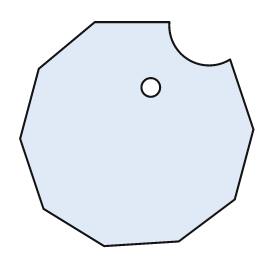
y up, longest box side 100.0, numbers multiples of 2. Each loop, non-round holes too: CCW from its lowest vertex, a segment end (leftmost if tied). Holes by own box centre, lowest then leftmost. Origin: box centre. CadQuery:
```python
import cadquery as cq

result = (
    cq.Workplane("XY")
    .moveTo(-14.0, -48.0)
    .lineTo(18.0, -46.0)
    .lineTo(42.0, -28.0)
    .lineTo(50.0, 2.0)
    .lineTo(40.0, 32.0)
    .threePointArc((22.0, 32.0), (14.0, 48.0))
    .lineTo(-18.0, 48.0)
    .lineTo(-42.0, 28.0)
    .lineTo(-50.0, -2.0)
    .lineTo(-40.0, -32.0)
    .close()
    .moveTo(6.0, 20.0)
    .circle(4.0)
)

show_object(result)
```